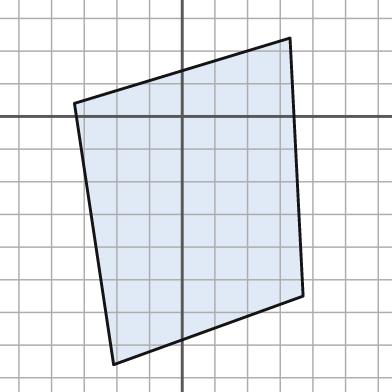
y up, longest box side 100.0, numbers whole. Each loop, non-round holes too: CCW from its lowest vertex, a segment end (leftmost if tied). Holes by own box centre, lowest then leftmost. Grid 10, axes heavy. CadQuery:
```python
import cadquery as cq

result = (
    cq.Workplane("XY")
    .moveTo(-21.0, -76.0)
    .lineTo(37.0, -55.0)
    .lineTo(33.0, 24.0)
    .lineTo(-33.0, 4.0)
    .close()
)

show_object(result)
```